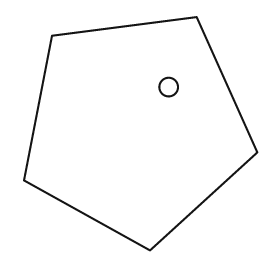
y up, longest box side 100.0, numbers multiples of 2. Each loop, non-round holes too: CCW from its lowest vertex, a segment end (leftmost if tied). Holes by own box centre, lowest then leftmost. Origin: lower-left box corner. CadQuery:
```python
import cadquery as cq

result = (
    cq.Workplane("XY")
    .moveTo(54.0, 0.0)
    .lineTo(100.0, 42.0)
    .lineTo(74.0, 100.0)
    .lineTo(12.0, 92.0)
    .lineTo(0.0, 30.0)
    .close()
    .moveTo(62.0, 70.0)
    .circle(4.0)
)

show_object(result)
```